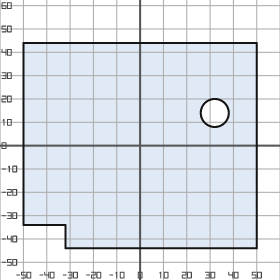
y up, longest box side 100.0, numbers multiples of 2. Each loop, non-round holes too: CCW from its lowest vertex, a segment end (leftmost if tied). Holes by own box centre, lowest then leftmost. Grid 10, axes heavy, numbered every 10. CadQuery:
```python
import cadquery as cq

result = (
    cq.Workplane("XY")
    .moveTo(-32.0, -44.0)
    .lineTo(50.0, -44.0)
    .lineTo(50.0, 44.0)
    .lineTo(-50.0, 44.0)
    .lineTo(-50.0, -34.0)
    .lineTo(-32.0, -34.0)
    .close()
    .moveTo(32.0, 14.0)
    .circle(6.0)
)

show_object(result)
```